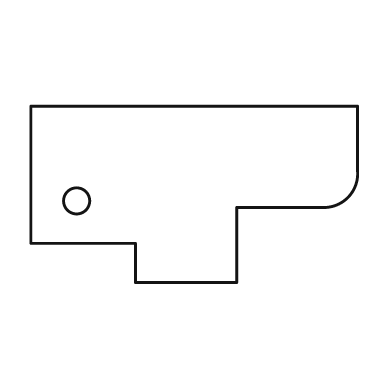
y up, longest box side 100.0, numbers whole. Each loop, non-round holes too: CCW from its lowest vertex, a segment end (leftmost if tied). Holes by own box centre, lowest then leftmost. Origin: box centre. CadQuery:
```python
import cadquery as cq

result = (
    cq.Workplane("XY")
    .moveTo(-18.0, -27.0)
    .lineTo(13.0, -27.0)
    .lineTo(13.0, -4.0)
    .lineTo(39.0, -4.0)
    .threePointArc((47.0, -1.0), (50.0, 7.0))
    .lineTo(50.0, 27.0)
    .lineTo(-50.0, 27.0)
    .lineTo(-50.0, -15.0)
    .lineTo(-18.0, -15.0)
    .close()
    .moveTo(-36.0, -2.0)
    .circle(4.0)
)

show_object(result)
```